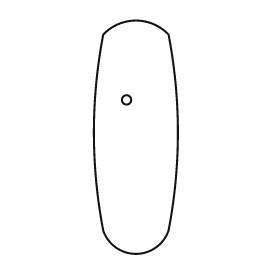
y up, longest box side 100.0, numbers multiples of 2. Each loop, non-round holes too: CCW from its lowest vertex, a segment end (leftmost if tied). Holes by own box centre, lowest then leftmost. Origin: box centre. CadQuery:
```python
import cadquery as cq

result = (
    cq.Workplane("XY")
    .moveTo(-14.0, -40.0)
    .threePointArc((0.0, -50.0), (14.0, -40.0))
    .threePointArc((18.0, 2.0), (14.0, 44.0))
    .threePointArc((0.0, 50.0), (-14.0, 44.0))
    .threePointArc((-18.0, 2.0), (-14.0, -40.0))
    .close()
    .moveTo(-4.0, 16.0)
    .circle(2.0)
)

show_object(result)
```